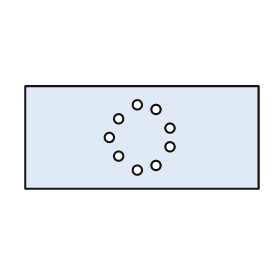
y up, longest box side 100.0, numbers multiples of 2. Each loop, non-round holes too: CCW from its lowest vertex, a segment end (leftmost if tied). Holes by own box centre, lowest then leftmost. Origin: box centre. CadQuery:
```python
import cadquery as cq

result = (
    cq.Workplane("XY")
    .moveTo(-50.0, -22.0)
    .lineTo(50.0, -22.0)
    .lineTo(50.0, 22.0)
    .lineTo(-50.0, 22.0)
    .close()
    .moveTo(-2.0, -14.0)
    .circle(2.0)
    .moveTo(6.0, -12.0)
    .circle(2.0)
    .moveTo(-10.0, -8.0)
    .circle(2.0)
    .moveTo(12.0, -4.0)
    .circle(2.0)
    .moveTo(-14.0, 0.0)
    .circle(2.0)
    .moveTo(12.0, 4.0)
    .circle(2.0)
    .moveTo(-10.0, 8.0)
    .circle(2.0)
    .moveTo(6.0, 12.0)
    .circle(2.0)
    .moveTo(-2.0, 14.0)
    .circle(2.0)
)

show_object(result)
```